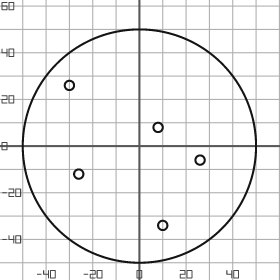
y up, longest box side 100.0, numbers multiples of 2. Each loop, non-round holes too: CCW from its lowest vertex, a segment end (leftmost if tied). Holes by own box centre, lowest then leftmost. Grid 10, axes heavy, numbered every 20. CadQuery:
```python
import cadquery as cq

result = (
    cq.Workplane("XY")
    .moveTo(0.0, 0.0)
    .circle(50.0)
    .moveTo(10.0, -34.0)
    .circle(2.0)
    .moveTo(-26.0, -12.0)
    .circle(2.0)
    .moveTo(26.0, -6.0)
    .circle(2.0)
    .moveTo(8.0, 8.0)
    .circle(2.0)
    .moveTo(-30.0, 26.0)
    .circle(2.0)
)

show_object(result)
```